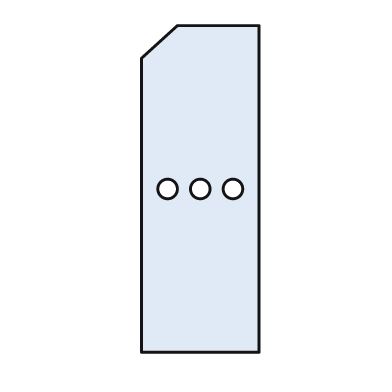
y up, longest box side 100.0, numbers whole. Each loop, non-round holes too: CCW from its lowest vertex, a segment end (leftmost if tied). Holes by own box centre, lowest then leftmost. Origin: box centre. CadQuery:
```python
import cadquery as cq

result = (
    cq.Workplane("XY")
    .moveTo(-18.0, -50.0)
    .lineTo(18.0, -50.0)
    .lineTo(18.0, 50.0)
    .lineTo(-7.0, 50.0)
    .lineTo(-18.0, 40.0)
    .close()
    .moveTo(-10.0, 0.0)
    .circle(3.0)
    .moveTo(0.0, 0.0)
    .circle(3.0)
    .moveTo(10.0, 0.0)
    .circle(3.0)
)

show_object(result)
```